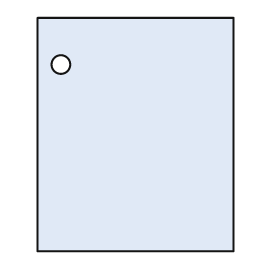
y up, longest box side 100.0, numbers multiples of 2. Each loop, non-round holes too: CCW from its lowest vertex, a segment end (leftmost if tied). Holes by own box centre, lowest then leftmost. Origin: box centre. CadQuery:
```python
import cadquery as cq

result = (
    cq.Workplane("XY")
    .moveTo(-42.0, -50.0)
    .lineTo(42.0, -50.0)
    .lineTo(42.0, 50.0)
    .lineTo(-42.0, 50.0)
    .close()
    .moveTo(-32.0, 30.0)
    .circle(4.0)
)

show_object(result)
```